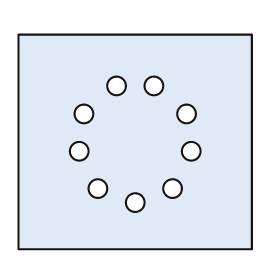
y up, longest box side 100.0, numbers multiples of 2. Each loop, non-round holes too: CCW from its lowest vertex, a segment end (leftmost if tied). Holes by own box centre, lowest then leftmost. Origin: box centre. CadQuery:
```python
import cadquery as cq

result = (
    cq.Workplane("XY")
    .moveTo(-50.0, -46.0)
    .lineTo(50.0, -46.0)
    .lineTo(50.0, 46.0)
    .lineTo(-50.0, 46.0)
    .close()
    .moveTo(0.0, -26.0)
    .circle(4.0)
    .moveTo(-16.0, -20.0)
    .circle(4.0)
    .moveTo(16.0, -20.0)
    .circle(4.0)
    .moveTo(-24.0, -4.0)
    .circle(4.0)
    .moveTo(24.0, -4.0)
    .circle(4.0)
    .moveTo(-22.0, 12.0)
    .circle(4.0)
    .moveTo(22.0, 12.0)
    .circle(4.0)
    .moveTo(-8.0, 24.0)
    .circle(4.0)
    .moveTo(8.0, 24.0)
    .circle(4.0)
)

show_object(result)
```